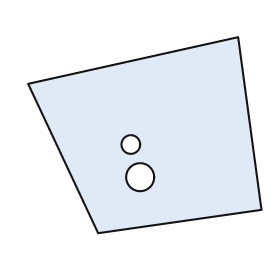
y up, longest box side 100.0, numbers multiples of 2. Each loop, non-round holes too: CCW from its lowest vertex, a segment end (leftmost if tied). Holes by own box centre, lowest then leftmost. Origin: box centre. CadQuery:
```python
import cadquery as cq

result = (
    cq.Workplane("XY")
    .moveTo(-20.0, -42.0)
    .lineTo(50.0, -32.0)
    .lineTo(40.0, 42.0)
    .lineTo(-50.0, 22.0)
    .close()
    .moveTo(-2.0, -18.0)
    .circle(6.0)
    .moveTo(-6.0, -4.0)
    .circle(4.0)
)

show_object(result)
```